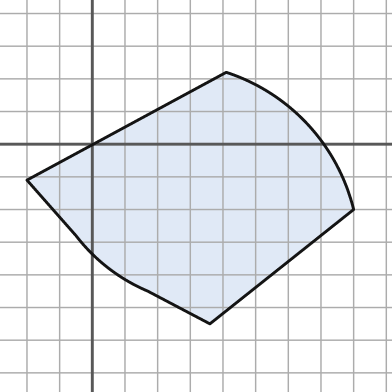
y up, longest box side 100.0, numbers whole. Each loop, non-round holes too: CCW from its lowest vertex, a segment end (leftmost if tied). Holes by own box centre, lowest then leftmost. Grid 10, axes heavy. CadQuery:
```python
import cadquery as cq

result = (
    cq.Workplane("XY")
    .moveTo(36.0, -55.0)
    .lineTo(80.0, -20.0)
    .threePointArc((66.0, 6.0), (41.0, 22.0))
    .lineTo(-20.0, -11.0)
    .lineTo(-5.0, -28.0)
    .threePointArc((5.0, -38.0), (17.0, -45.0))
    .close()
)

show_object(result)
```